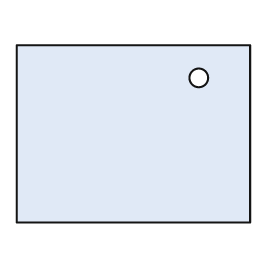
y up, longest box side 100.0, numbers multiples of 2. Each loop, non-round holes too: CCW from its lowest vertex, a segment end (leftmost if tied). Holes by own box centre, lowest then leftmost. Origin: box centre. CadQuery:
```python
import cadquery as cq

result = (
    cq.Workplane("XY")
    .moveTo(-50.0, -38.0)
    .lineTo(50.0, -38.0)
    .lineTo(50.0, 38.0)
    .lineTo(-50.0, 38.0)
    .close()
    .moveTo(28.0, 24.0)
    .circle(4.0)
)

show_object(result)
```